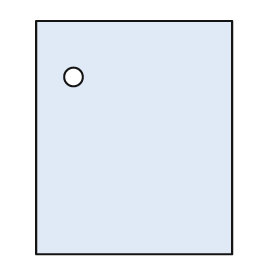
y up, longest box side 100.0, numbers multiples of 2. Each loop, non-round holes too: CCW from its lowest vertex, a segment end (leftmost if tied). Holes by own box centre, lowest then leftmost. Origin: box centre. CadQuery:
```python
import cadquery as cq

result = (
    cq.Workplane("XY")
    .moveTo(-42.0, -50.0)
    .lineTo(42.0, -50.0)
    .lineTo(42.0, 50.0)
    .lineTo(-42.0, 50.0)
    .close()
    .moveTo(-26.0, 26.0)
    .circle(4.0)
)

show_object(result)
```